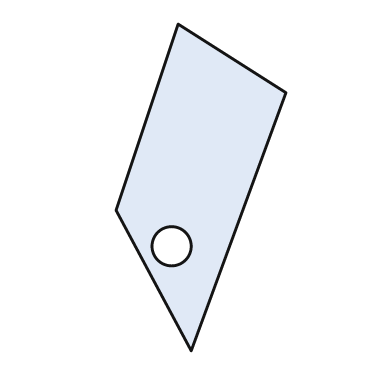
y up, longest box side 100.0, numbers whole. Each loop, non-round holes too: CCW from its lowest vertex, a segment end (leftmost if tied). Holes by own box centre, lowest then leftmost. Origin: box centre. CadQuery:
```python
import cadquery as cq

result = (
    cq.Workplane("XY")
    .moveTo(-3.0, -50.0)
    .lineTo(26.0, 29.0)
    .lineTo(-7.0, 50.0)
    .lineTo(-26.0, -7.0)
    .close()
    .moveTo(-9.0, -18.0)
    .circle(6.0)
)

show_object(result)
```